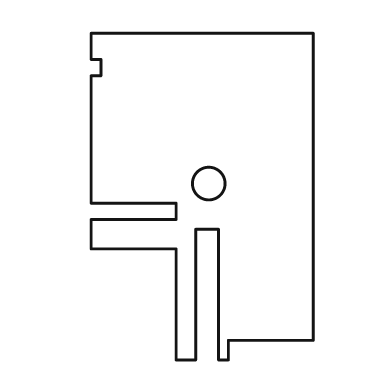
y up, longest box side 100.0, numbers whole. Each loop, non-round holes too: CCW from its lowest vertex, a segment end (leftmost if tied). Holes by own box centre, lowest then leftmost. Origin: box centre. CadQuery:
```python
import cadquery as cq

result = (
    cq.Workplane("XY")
    .moveTo(-8.0, -50.0)
    .lineTo(-2.0, -50.0)
    .lineTo(-2.0, -10.0)
    .lineTo(5.0, -10.0)
    .lineTo(5.0, -50.0)
    .lineTo(8.0, -50.0)
    .lineTo(8.0, -44.0)
    .lineTo(34.0, -44.0)
    .lineTo(34.0, 50.0)
    .lineTo(-34.0, 50.0)
    .lineTo(-34.0, 42.0)
    .lineTo(-31.0, 42.0)
    .lineTo(-31.0, 37.0)
    .lineTo(-34.0, 37.0)
    .lineTo(-34.0, -2.0)
    .lineTo(-8.0, -2.0)
    .lineTo(-8.0, -7.0)
    .lineTo(-34.0, -7.0)
    .lineTo(-34.0, -16.0)
    .lineTo(-8.0, -16.0)
    .close()
    .moveTo(2.0, 4.0)
    .circle(5.0)
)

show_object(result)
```